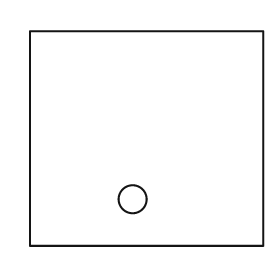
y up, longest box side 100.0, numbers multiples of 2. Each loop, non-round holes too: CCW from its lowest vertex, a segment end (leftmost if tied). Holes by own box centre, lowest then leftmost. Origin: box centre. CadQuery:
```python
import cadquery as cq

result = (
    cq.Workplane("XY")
    .moveTo(-50.0, -46.0)
    .lineTo(50.0, -46.0)
    .lineTo(50.0, 46.0)
    .lineTo(-50.0, 46.0)
    .close()
    .moveTo(-6.0, -26.0)
    .circle(6.0)
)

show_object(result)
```